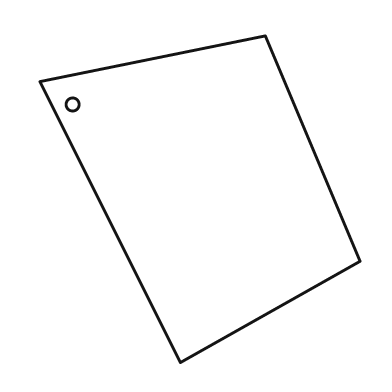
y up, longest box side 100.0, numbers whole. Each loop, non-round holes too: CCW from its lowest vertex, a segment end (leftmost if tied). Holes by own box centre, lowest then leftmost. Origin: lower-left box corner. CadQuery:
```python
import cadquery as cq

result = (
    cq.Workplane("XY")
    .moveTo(43.0, 0.0)
    .lineTo(98.0, 31.0)
    .lineTo(69.0, 100.0)
    .lineTo(0.0, 86.0)
    .close()
    .moveTo(10.0, 79.0)
    .circle(2.0)
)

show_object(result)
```